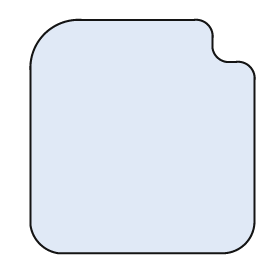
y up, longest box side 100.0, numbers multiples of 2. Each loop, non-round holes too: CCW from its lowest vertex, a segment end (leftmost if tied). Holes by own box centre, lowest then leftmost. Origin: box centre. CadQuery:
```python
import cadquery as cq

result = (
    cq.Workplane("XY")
    .moveTo(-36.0, -50.0)
    .lineTo(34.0, -50.0)
    .threePointArc((44.0, -46.0), (48.0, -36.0))
    .lineTo(48.0, 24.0)
    .threePointArc((46.0, 30.0), (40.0, 32.0))
    .lineTo(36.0, 32.0)
    .threePointArc((32.0, 34.0), (30.0, 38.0))
    .lineTo(30.0, 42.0)
    .threePointArc((28.0, 48.0), (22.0, 50.0))
    .lineTo(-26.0, 50.0)
    .threePointArc((-42.0, 44.0), (-48.0, 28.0))
    .lineTo(-48.0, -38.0)
    .threePointArc((-44.0, -46.0), (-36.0, -50.0))
    .close()
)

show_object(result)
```